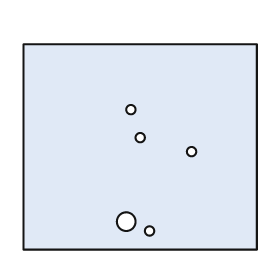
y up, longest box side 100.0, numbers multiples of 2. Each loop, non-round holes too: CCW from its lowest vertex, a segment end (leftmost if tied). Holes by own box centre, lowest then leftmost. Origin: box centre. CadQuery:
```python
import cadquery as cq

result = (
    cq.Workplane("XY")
    .moveTo(-50.0, -44.0)
    .lineTo(50.0, -44.0)
    .lineTo(50.0, 44.0)
    .lineTo(-50.0, 44.0)
    .close()
    .moveTo(4.0, -36.0)
    .circle(2.0)
    .moveTo(-6.0, -32.0)
    .circle(4.0)
    .moveTo(22.0, -2.0)
    .circle(2.0)
    .moveTo(0.0, 4.0)
    .circle(2.0)
    .moveTo(-4.0, 16.0)
    .circle(2.0)
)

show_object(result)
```